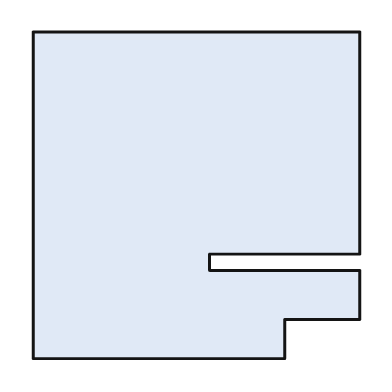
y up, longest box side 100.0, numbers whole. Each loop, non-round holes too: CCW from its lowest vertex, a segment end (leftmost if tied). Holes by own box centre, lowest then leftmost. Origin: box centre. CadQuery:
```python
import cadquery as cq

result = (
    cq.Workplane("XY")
    .moveTo(-50.0, -50.0)
    .lineTo(27.0, -50.0)
    .lineTo(27.0, -38.0)
    .lineTo(50.0, -38.0)
    .lineTo(50.0, -23.0)
    .lineTo(4.0, -23.0)
    .lineTo(4.0, -18.0)
    .lineTo(50.0, -18.0)
    .lineTo(50.0, 50.0)
    .lineTo(-50.0, 50.0)
    .close()
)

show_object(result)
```